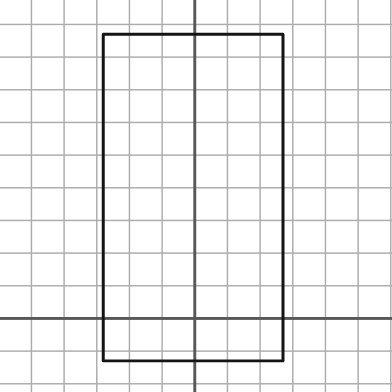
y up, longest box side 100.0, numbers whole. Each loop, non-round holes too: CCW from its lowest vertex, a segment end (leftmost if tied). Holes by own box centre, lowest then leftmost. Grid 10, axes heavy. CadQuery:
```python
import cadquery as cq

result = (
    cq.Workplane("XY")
    .moveTo(-28.0, -13.0)
    .lineTo(27.0, -13.0)
    .lineTo(27.0, 87.0)
    .lineTo(-28.0, 87.0)
    .close()
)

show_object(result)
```